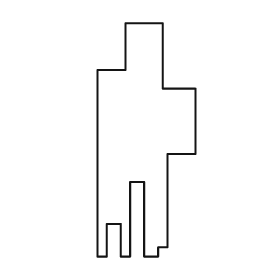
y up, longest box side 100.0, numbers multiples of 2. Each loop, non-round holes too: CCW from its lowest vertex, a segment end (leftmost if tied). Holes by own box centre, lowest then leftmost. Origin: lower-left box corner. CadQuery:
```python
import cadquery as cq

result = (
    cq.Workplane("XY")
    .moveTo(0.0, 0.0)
    .lineTo(4.0, 0.0)
    .lineTo(4.0, 14.0)
    .lineTo(10.0, 14.0)
    .lineTo(10.0, 0.0)
    .lineTo(14.0, 0.0)
    .lineTo(14.0, 32.0)
    .lineTo(20.0, 32.0)
    .lineTo(20.0, 0.0)
    .lineTo(26.0, 0.0)
    .lineTo(26.0, 4.0)
    .lineTo(30.0, 4.0)
    .lineTo(30.0, 44.0)
    .lineTo(42.0, 44.0)
    .lineTo(42.0, 72.0)
    .lineTo(28.0, 72.0)
    .lineTo(28.0, 100.0)
    .lineTo(12.0, 100.0)
    .lineTo(12.0, 80.0)
    .lineTo(0.0, 80.0)
    .close()
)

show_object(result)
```